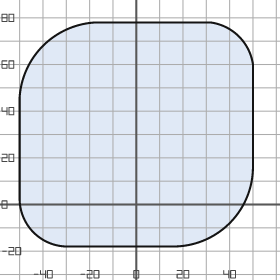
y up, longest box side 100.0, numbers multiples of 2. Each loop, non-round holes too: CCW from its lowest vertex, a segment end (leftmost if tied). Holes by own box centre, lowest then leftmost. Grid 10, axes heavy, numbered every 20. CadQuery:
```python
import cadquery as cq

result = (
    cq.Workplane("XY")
    .moveTo(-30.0, -18.0)
    .lineTo(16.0, -18.0)
    .threePointArc((40.0, -8.0), (50.0, 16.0))
    .lineTo(50.0, 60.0)
    .threePointArc((44.0, 72.0), (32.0, 78.0))
    .lineTo(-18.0, 78.0)
    .threePointArc((-40.0, 68.0), (-50.0, 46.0))
    .lineTo(-50.0, 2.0)
    .threePointArc((-44.0, -12.0), (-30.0, -18.0))
    .close()
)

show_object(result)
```